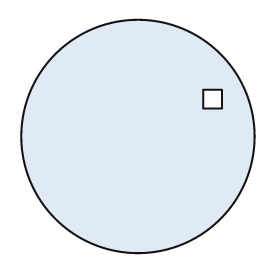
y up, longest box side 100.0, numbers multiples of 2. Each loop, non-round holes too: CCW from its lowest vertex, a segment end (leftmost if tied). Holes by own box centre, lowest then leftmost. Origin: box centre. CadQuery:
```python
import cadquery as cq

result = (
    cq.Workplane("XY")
    .moveTo(0.0, 0.0)
    .circle(50.0)
    .moveTo(28.0, 12.0)
    .lineTo(36.0, 12.0)
    .lineTo(36.0, 20.0)
    .lineTo(28.0, 20.0)
    .close()
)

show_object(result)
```